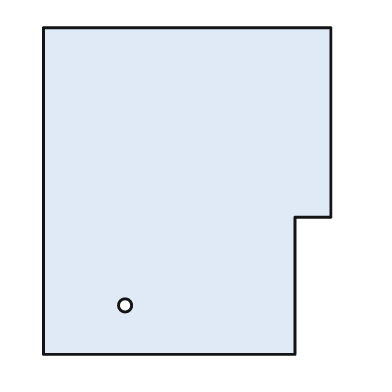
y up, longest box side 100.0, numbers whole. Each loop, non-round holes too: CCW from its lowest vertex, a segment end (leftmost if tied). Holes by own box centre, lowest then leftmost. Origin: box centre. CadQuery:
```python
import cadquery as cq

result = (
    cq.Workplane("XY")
    .moveTo(-44.0, -50.0)
    .lineTo(33.0, -50.0)
    .lineTo(33.0, -8.0)
    .lineTo(44.0, -8.0)
    .lineTo(44.0, 50.0)
    .lineTo(-44.0, 50.0)
    .close()
    .moveTo(-19.0, -35.0)
    .circle(2.0)
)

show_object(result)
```